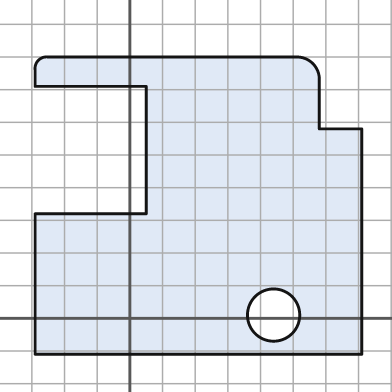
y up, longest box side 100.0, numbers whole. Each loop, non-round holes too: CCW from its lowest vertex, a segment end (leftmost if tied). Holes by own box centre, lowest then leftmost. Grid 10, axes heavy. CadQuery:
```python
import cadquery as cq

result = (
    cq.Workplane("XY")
    .moveTo(-29.0, -11.0)
    .lineTo(71.0, -11.0)
    .lineTo(71.0, 58.0)
    .lineTo(58.0, 58.0)
    .lineTo(58.0, 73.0)
    .threePointArc((56.0, 78.0), (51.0, 80.0))
    .lineTo(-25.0, 80.0)
    .threePointArc((-28.0, 79.0), (-29.0, 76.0))
    .lineTo(-29.0, 71.0)
    .lineTo(5.0, 71.0)
    .lineTo(5.0, 32.0)
    .lineTo(-29.0, 32.0)
    .close()
    .moveTo(44.0, 1.0)
    .circle(8.0)
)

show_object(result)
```